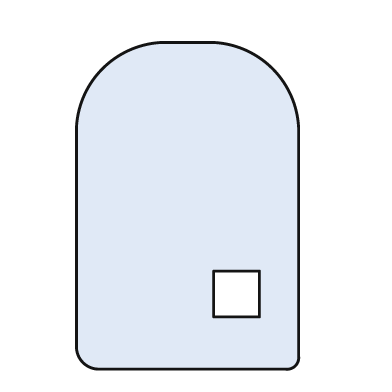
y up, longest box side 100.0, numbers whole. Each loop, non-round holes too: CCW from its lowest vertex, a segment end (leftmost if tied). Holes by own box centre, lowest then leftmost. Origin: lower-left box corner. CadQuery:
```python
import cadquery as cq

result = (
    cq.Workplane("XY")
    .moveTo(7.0, 0.0)
    .lineTo(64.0, 0.0)
    .threePointArc((67.0, 1.0), (68.0, 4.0))
    .lineTo(68.0, 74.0)
    .threePointArc((60.0, 92.0), (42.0, 100.0))
    .lineTo(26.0, 100.0)
    .threePointArc((8.0, 92.0), (0.0, 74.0))
    .lineTo(0.0, 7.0)
    .threePointArc((2.0, 2.0), (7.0, 0.0))
    .close()
    .moveTo(42.0, 16.0)
    .lineTo(56.0, 16.0)
    .lineTo(56.0, 30.0)
    .lineTo(42.0, 30.0)
    .close()
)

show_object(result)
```